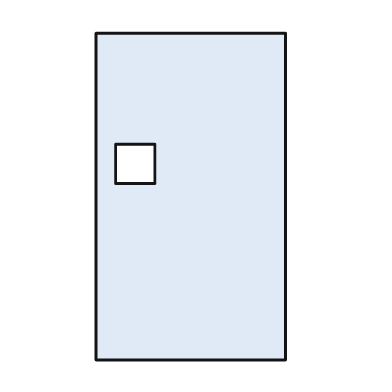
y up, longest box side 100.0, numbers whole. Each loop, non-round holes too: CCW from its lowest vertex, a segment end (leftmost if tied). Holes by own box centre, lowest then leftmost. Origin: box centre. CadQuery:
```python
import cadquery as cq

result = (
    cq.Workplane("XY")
    .moveTo(-29.0, -50.0)
    .lineTo(29.0, -50.0)
    .lineTo(29.0, 50.0)
    .lineTo(-29.0, 50.0)
    .close()
    .moveTo(-23.0, 4.0)
    .lineTo(-11.0, 4.0)
    .lineTo(-11.0, 16.0)
    .lineTo(-23.0, 16.0)
    .close()
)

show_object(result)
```